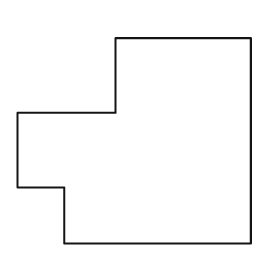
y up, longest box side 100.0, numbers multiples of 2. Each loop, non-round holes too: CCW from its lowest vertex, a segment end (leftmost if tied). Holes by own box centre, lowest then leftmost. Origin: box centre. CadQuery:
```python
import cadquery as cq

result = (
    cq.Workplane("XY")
    .moveTo(-30.0, -44.0)
    .lineTo(50.0, -44.0)
    .lineTo(50.0, 44.0)
    .lineTo(-8.0, 44.0)
    .lineTo(-8.0, 12.0)
    .lineTo(-50.0, 12.0)
    .lineTo(-50.0, -20.0)
    .lineTo(-30.0, -20.0)
    .close()
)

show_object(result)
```